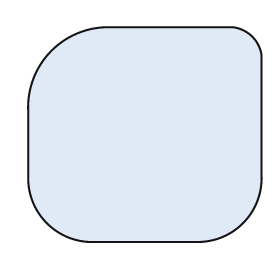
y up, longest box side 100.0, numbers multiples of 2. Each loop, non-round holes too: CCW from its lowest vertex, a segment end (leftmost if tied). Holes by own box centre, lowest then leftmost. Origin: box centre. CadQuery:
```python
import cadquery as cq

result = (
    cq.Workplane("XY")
    .moveTo(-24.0, -46.0)
    .lineTo(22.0, -46.0)
    .threePointArc((42.0, -38.0), (50.0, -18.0))
    .lineTo(50.0, 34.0)
    .threePointArc((46.0, 42.0), (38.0, 46.0))
    .lineTo(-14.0, 46.0)
    .threePointArc((-40.0, 36.0), (-50.0, 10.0))
    .lineTo(-50.0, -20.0)
    .threePointArc((-42.0, -38.0), (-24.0, -46.0))
    .close()
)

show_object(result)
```